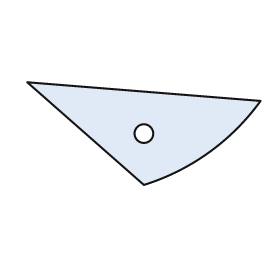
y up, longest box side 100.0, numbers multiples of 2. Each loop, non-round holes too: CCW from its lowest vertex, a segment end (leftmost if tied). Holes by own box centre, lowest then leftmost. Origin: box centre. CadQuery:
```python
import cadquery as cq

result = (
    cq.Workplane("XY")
    .moveTo(0.0, -22.0)
    .threePointArc((28.0, -8.0), (50.0, 14.0))
    .lineTo(-50.0, 22.0)
    .close()
    .moveTo(0.0, 0.0)
    .circle(4.0)
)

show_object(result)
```